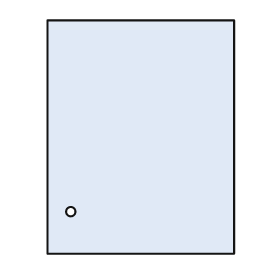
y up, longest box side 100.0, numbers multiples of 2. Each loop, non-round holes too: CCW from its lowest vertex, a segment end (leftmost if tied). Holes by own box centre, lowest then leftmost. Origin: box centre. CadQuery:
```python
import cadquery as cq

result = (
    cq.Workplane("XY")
    .moveTo(-40.0, -50.0)
    .lineTo(40.0, -50.0)
    .lineTo(40.0, 50.0)
    .lineTo(-40.0, 50.0)
    .close()
    .moveTo(-30.0, -32.0)
    .circle(2.0)
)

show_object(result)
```